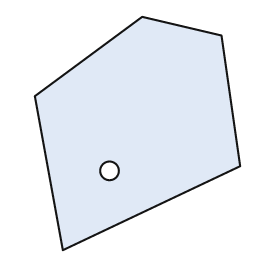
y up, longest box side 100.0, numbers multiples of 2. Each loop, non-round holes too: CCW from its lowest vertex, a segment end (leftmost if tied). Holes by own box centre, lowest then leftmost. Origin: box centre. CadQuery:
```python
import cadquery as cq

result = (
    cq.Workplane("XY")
    .moveTo(-32.0, -50.0)
    .lineTo(44.0, -14.0)
    .lineTo(36.0, 42.0)
    .lineTo(2.0, 50.0)
    .lineTo(-44.0, 16.0)
    .close()
    .moveTo(-12.0, -16.0)
    .circle(4.0)
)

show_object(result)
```